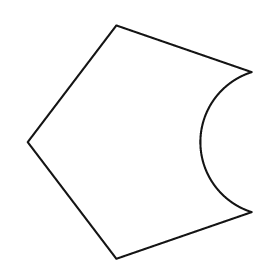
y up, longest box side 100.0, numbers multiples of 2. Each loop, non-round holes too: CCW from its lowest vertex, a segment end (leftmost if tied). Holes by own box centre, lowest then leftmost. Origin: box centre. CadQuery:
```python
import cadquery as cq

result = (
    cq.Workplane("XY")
    .moveTo(-10.0, -50.0)
    .lineTo(48.0, -30.0)
    .threePointArc((26.0, 0.0), (48.0, 30.0))
    .lineTo(-10.0, 50.0)
    .lineTo(-48.0, 0.0)
    .close()
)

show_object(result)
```